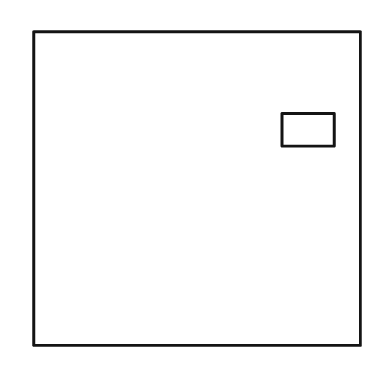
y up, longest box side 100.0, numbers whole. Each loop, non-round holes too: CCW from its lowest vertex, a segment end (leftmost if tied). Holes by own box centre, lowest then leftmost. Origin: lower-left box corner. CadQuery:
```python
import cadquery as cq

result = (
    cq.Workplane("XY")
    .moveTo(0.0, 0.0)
    .lineTo(100.0, 0.0)
    .lineTo(100.0, 96.0)
    .lineTo(0.0, 96.0)
    .close()
    .moveTo(76.0, 61.0)
    .lineTo(92.0, 61.0)
    .lineTo(92.0, 71.0)
    .lineTo(76.0, 71.0)
    .close()
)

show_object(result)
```